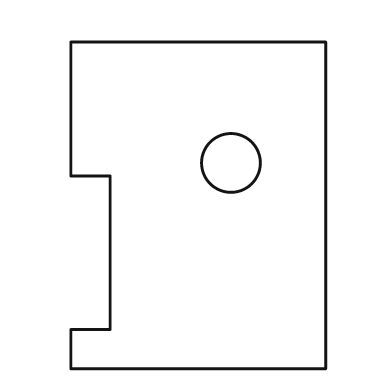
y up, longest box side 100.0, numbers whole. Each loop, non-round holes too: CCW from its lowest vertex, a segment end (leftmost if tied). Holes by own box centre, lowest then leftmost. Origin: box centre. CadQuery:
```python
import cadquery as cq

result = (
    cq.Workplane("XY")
    .moveTo(-39.0, -50.0)
    .lineTo(39.0, -50.0)
    .lineTo(39.0, 50.0)
    .lineTo(-39.0, 50.0)
    .lineTo(-39.0, 9.0)
    .lineTo(-27.0, 9.0)
    .lineTo(-27.0, -38.0)
    .lineTo(-39.0, -38.0)
    .close()
    .moveTo(10.0, 13.0)
    .circle(9.0)
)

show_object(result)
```